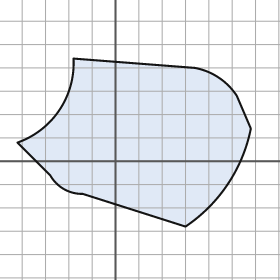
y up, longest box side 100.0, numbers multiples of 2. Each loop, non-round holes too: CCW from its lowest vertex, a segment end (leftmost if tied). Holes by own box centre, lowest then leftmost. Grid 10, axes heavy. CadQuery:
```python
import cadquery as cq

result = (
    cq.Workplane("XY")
    .moveTo(30.0, -28.0)
    .threePointArc((48.0, -10.0), (58.0, 14.0))
    .lineTo(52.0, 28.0)
    .threePointArc((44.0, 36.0), (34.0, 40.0))
    .lineTo(-18.0, 44.0)
    .threePointArc((-24.0, 22.0), (-42.0, 8.0))
    .lineTo(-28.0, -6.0)
    .threePointArc((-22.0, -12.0), (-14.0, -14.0))
    .close()
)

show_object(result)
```